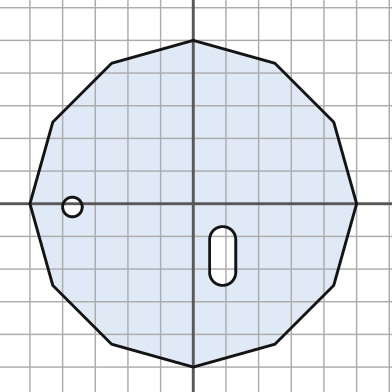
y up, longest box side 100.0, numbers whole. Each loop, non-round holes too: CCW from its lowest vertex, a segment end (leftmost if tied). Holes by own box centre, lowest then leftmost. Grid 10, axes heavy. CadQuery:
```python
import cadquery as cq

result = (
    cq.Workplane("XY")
    .moveTo(0.0, -50.0)
    .lineTo(25.0, -43.0)
    .lineTo(43.0, -25.0)
    .lineTo(50.0, 0.0)
    .lineTo(43.0, 25.0)
    .lineTo(25.0, 43.0)
    .lineTo(0.0, 50.0)
    .lineTo(-25.0, 43.0)
    .lineTo(-43.0, 25.0)
    .lineTo(-50.0, 0.0)
    .lineTo(-43.0, -25.0)
    .lineTo(-25.0, -43.0)
    .close()
    .moveTo(5.0, -21.0)
    .threePointArc((9.0, -25.0), (13.0, -21.0))
    .lineTo(13.0, -11.0)
    .threePointArc((9.0, -7.0), (5.0, -11.0))
    .close()
    .moveTo(-37.0, -1.0)
    .circle(3.0)
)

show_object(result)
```